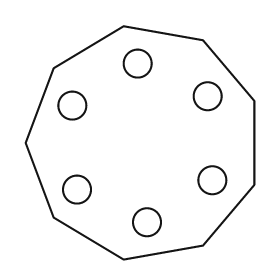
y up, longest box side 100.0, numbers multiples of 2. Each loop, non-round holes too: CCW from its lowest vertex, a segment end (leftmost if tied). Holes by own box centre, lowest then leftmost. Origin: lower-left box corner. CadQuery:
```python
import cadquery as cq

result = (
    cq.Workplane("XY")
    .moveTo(42.0, 0.0)
    .lineTo(76.0, 6.0)
    .lineTo(98.0, 32.0)
    .lineTo(98.0, 68.0)
    .lineTo(76.0, 94.0)
    .lineTo(42.0, 100.0)
    .lineTo(12.0, 82.0)
    .lineTo(0.0, 50.0)
    .lineTo(12.0, 18.0)
    .close()
    .moveTo(52.0, 16.0)
    .circle(6.0)
    .moveTo(22.0, 30.0)
    .circle(6.0)
    .moveTo(80.0, 34.0)
    .circle(6.0)
    .moveTo(20.0, 66.0)
    .circle(6.0)
    .moveTo(78.0, 70.0)
    .circle(6.0)
    .moveTo(48.0, 84.0)
    .circle(6.0)
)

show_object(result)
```